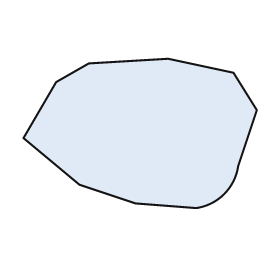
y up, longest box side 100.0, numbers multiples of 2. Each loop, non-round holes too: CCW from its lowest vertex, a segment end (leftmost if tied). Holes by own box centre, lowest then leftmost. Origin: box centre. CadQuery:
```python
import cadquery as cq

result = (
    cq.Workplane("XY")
    .moveTo(24.0, -32.0)
    .threePointArc((36.0, -26.0), (42.0, -14.0))
    .lineTo(50.0, 10.0)
    .lineTo(40.0, 26.0)
    .lineTo(12.0, 32.0)
    .lineTo(-22.0, 30.0)
    .lineTo(-36.0, 22.0)
    .lineTo(-50.0, -2.0)
    .lineTo(-26.0, -22.0)
    .lineTo(-2.0, -30.0)
    .close()
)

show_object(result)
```